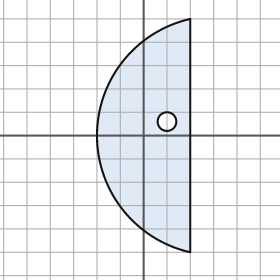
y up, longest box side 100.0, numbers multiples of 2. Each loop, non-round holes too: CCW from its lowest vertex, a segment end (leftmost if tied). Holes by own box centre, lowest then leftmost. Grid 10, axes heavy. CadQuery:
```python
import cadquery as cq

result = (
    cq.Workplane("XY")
    .moveTo(20.0, -50.0)
    .lineTo(20.0, 50.0)
    .threePointArc((-20.0, 0.0), (20.0, -50.0))
    .close()
    .moveTo(10.0, 6.0)
    .circle(4.0)
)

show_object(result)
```